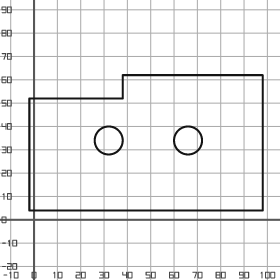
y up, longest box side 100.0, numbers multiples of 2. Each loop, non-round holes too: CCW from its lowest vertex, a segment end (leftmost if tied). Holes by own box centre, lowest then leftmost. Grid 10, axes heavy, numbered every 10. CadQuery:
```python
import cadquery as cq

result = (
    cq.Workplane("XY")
    .moveTo(-2.0, 4.0)
    .lineTo(98.0, 4.0)
    .lineTo(98.0, 62.0)
    .lineTo(38.0, 62.0)
    .lineTo(38.0, 52.0)
    .lineTo(-2.0, 52.0)
    .close()
    .moveTo(32.0, 34.0)
    .circle(6.0)
    .moveTo(66.0, 34.0)
    .circle(6.0)
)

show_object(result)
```